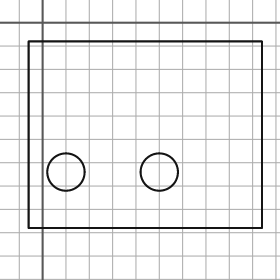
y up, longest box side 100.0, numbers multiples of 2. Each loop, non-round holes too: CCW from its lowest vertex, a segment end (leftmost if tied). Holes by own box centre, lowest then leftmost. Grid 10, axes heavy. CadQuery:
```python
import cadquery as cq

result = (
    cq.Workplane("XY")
    .moveTo(-6.0, -88.0)
    .lineTo(94.0, -88.0)
    .lineTo(94.0, -8.0)
    .lineTo(-6.0, -8.0)
    .close()
    .moveTo(10.0, -64.0)
    .circle(8.0)
    .moveTo(50.0, -64.0)
    .circle(8.0)
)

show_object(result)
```